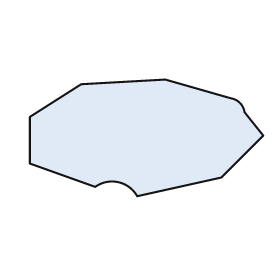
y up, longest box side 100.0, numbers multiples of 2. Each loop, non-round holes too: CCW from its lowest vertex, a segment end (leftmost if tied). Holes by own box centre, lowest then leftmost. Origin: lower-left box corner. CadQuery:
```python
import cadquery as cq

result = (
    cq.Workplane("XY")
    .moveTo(46.0, 0.0)
    .lineTo(82.0, 8.0)
    .lineTo(100.0, 26.0)
    .lineTo(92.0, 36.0)
    .threePointArc((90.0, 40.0), (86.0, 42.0))
    .lineTo(58.0, 50.0)
    .lineTo(22.0, 48.0)
    .lineTo(0.0, 34.0)
    .lineTo(0.0, 14.0)
    .lineTo(28.0, 4.0)
    .threePointArc((38.0, 6.0), (46.0, 0.0))
    .close()
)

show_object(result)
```